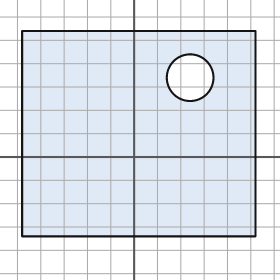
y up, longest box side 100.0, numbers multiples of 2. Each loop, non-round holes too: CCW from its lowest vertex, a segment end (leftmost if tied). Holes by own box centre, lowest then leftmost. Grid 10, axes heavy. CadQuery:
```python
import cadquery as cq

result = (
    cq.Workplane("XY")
    .moveTo(-48.0, -34.0)
    .lineTo(52.0, -34.0)
    .lineTo(52.0, 54.0)
    .lineTo(-48.0, 54.0)
    .close()
    .moveTo(24.0, 34.0)
    .circle(10.0)
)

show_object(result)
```